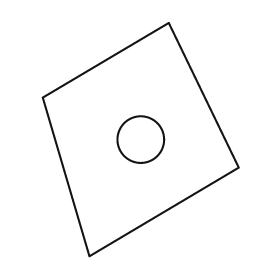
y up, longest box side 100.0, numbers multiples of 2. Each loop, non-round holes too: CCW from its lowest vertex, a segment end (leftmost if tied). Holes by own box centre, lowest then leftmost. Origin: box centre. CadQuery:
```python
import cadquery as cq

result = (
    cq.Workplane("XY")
    .moveTo(-22.0, -50.0)
    .lineTo(42.0, -12.0)
    .lineTo(12.0, 50.0)
    .lineTo(-42.0, 18.0)
    .close()
    .moveTo(0.0, 0.0)
    .circle(10.0)
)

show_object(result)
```